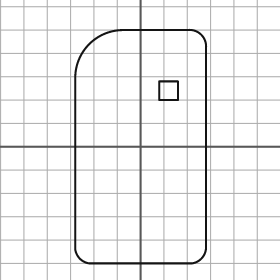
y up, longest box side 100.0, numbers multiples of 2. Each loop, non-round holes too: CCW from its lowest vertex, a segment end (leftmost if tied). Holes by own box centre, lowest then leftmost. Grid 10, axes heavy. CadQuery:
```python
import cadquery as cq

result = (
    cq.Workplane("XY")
    .moveTo(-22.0, -50.0)
    .lineTo(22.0, -50.0)
    .threePointArc((26.0, -48.0), (28.0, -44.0))
    .lineTo(28.0, 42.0)
    .threePointArc((26.0, 48.0), (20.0, 50.0))
    .lineTo(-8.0, 50.0)
    .threePointArc((-22.0, 44.0), (-28.0, 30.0))
    .lineTo(-28.0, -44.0)
    .threePointArc((-26.0, -48.0), (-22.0, -50.0))
    .close()
    .moveTo(8.0, 20.0)
    .lineTo(16.0, 20.0)
    .lineTo(16.0, 28.0)
    .lineTo(8.0, 28.0)
    .close()
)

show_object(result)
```